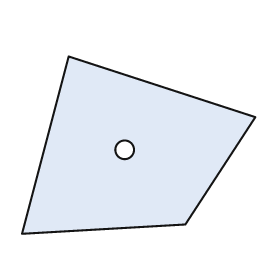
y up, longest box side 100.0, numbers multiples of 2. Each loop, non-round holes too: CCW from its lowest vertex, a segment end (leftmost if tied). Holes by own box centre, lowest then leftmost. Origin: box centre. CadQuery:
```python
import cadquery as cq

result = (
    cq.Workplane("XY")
    .moveTo(-50.0, -38.0)
    .lineTo(20.0, -34.0)
    .lineTo(50.0, 12.0)
    .lineTo(-30.0, 38.0)
    .close()
    .moveTo(-6.0, -2.0)
    .circle(4.0)
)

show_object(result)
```